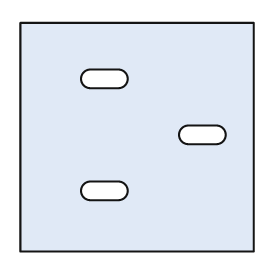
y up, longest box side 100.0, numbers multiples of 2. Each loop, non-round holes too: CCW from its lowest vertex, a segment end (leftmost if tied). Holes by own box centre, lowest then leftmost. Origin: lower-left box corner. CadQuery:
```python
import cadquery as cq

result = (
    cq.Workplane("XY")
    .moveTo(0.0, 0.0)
    .lineTo(100.0, 0.0)
    .lineTo(100.0, 98.0)
    .lineTo(0.0, 98.0)
    .close()
    .moveTo(30.0, 22.0)
    .lineTo(42.0, 22.0)
    .threePointArc((46.0, 26.0), (42.0, 30.0))
    .lineTo(30.0, 30.0)
    .threePointArc((26.0, 26.0), (30.0, 22.0))
    .close()
    .moveTo(72.0, 46.0)
    .lineTo(84.0, 46.0)
    .threePointArc((88.0, 50.0), (84.0, 54.0))
    .lineTo(72.0, 54.0)
    .threePointArc((68.0, 50.0), (72.0, 46.0))
    .close()
    .moveTo(30.0, 70.0)
    .lineTo(42.0, 70.0)
    .threePointArc((46.0, 74.0), (42.0, 78.0))
    .lineTo(30.0, 78.0)
    .threePointArc((26.0, 74.0), (30.0, 70.0))
    .close()
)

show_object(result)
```